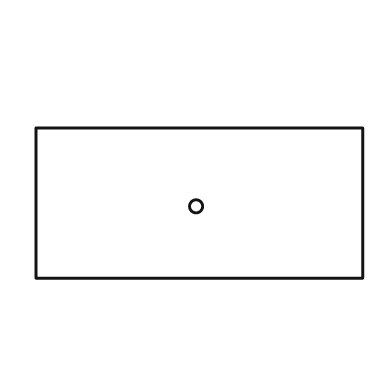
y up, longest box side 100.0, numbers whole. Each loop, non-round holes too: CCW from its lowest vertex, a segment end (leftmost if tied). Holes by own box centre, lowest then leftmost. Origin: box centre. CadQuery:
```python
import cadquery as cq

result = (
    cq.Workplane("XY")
    .moveTo(-50.0, -23.0)
    .lineTo(50.0, -23.0)
    .lineTo(50.0, 23.0)
    .lineTo(-50.0, 23.0)
    .close()
    .moveTo(-1.0, -1.0)
    .circle(2.0)
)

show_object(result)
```